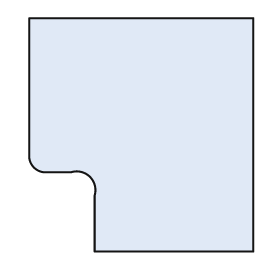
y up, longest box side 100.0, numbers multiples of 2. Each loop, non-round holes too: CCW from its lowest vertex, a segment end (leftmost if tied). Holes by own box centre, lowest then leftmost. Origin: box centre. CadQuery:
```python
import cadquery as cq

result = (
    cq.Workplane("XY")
    .moveTo(-20.0, -50.0)
    .lineTo(48.0, -50.0)
    .lineTo(48.0, 50.0)
    .lineTo(-48.0, 50.0)
    .lineTo(-48.0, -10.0)
    .threePointArc((-46.0, -14.0), (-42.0, -16.0))
    .lineTo(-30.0, -16.0)
    .threePointArc((-22.0, -18.0), (-20.0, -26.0))
    .close()
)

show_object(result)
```